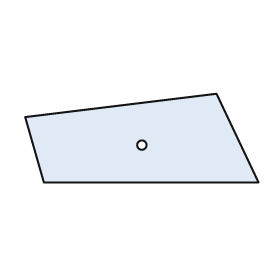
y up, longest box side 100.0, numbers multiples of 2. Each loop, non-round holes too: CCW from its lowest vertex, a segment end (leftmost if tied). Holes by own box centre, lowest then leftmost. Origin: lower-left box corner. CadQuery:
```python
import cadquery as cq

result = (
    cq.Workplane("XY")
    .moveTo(8.0, 0.0)
    .lineTo(100.0, 0.0)
    .lineTo(82.0, 38.0)
    .lineTo(0.0, 28.0)
    .close()
    .moveTo(50.0, 16.0)
    .circle(2.0)
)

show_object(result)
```